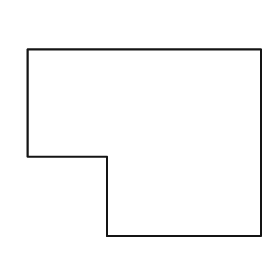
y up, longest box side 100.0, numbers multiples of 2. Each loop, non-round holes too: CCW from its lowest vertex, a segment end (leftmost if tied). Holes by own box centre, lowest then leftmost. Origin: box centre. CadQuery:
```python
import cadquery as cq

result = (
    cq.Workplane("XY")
    .moveTo(-16.0, -40.0)
    .lineTo(50.0, -40.0)
    .lineTo(50.0, 40.0)
    .lineTo(-50.0, 40.0)
    .lineTo(-50.0, -6.0)
    .lineTo(-16.0, -6.0)
    .close()
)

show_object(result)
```